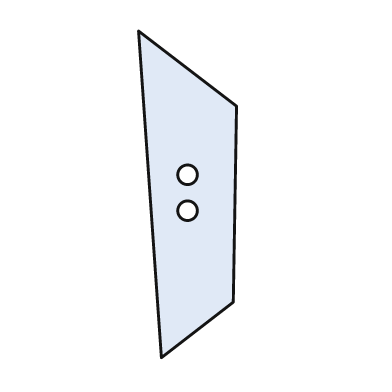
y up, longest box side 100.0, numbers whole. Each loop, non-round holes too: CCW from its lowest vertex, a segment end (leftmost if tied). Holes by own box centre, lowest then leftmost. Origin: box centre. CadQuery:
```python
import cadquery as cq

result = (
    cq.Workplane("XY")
    .moveTo(-8.0, -50.0)
    .lineTo(14.0, -33.0)
    .lineTo(15.0, 27.0)
    .lineTo(-15.0, 50.0)
    .close()
    .moveTo(0.0, -5.0)
    .circle(3.0)
    .moveTo(0.0, 6.0)
    .circle(3.0)
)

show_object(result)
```